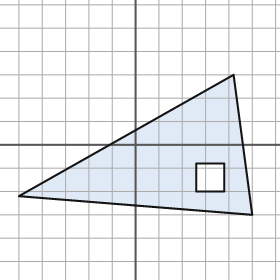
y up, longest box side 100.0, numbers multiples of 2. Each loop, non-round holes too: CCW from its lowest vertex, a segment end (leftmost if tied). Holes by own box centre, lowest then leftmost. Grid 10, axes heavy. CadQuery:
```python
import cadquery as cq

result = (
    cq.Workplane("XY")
    .moveTo(50.0, -30.0)
    .lineTo(42.0, 30.0)
    .lineTo(-50.0, -22.0)
    .close()
    .moveTo(26.0, -20.0)
    .lineTo(38.0, -20.0)
    .lineTo(38.0, -8.0)
    .lineTo(26.0, -8.0)
    .close()
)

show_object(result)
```